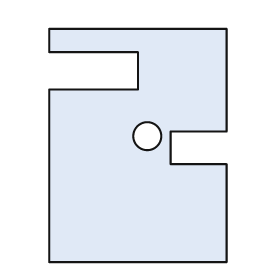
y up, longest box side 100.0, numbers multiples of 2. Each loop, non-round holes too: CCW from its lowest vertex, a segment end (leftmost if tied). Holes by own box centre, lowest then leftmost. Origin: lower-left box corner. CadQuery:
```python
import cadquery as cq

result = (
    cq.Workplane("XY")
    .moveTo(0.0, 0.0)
    .lineTo(76.0, 0.0)
    .lineTo(76.0, 42.0)
    .lineTo(52.0, 42.0)
    .lineTo(52.0, 56.0)
    .lineTo(76.0, 56.0)
    .lineTo(76.0, 100.0)
    .lineTo(0.0, 100.0)
    .lineTo(0.0, 90.0)
    .lineTo(38.0, 90.0)
    .lineTo(38.0, 74.0)
    .lineTo(0.0, 74.0)
    .close()
    .moveTo(42.0, 54.0)
    .circle(6.0)
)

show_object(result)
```